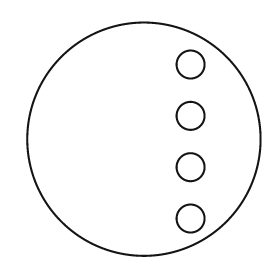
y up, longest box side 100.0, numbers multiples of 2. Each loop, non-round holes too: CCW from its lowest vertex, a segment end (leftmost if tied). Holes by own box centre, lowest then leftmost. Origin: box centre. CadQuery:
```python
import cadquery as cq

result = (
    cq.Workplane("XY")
    .moveTo(0.0, 0.0)
    .circle(50.0)
    .moveTo(20.0, -34.0)
    .circle(6.0)
    .moveTo(20.0, -12.0)
    .circle(6.0)
    .moveTo(20.0, 10.0)
    .circle(6.0)
    .moveTo(20.0, 32.0)
    .circle(6.0)
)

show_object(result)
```